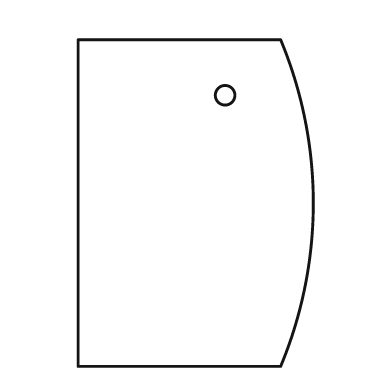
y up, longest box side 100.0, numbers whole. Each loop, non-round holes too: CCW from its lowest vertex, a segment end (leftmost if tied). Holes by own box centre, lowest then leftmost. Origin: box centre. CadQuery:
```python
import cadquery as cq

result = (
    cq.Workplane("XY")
    .moveTo(-36.0, -50.0)
    .lineTo(26.0, -50.0)
    .threePointArc((36.0, 0.0), (26.0, 50.0))
    .lineTo(-36.0, 50.0)
    .close()
    .moveTo(9.0, 33.0)
    .circle(3.0)
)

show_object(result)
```